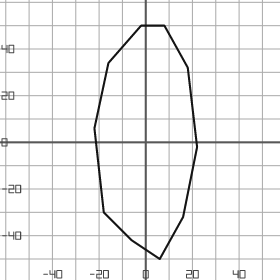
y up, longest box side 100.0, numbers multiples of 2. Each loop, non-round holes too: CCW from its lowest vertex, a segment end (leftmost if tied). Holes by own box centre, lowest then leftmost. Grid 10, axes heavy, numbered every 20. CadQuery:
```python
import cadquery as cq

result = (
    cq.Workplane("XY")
    .moveTo(6.0, -50.0)
    .lineTo(16.0, -32.0)
    .lineTo(22.0, -2.0)
    .lineTo(18.0, 32.0)
    .lineTo(8.0, 50.0)
    .lineTo(-2.0, 50.0)
    .lineTo(-16.0, 34.0)
    .lineTo(-22.0, 6.0)
    .lineTo(-18.0, -30.0)
    .lineTo(-6.0, -42.0)
    .close()
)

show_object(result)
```